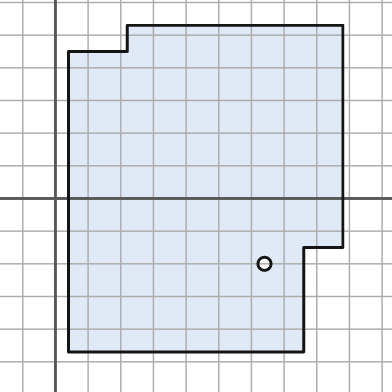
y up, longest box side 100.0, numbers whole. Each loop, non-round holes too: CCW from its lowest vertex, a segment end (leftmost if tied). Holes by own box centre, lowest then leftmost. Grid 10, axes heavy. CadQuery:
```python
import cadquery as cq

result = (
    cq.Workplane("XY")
    .moveTo(4.0, -47.0)
    .lineTo(76.0, -47.0)
    .lineTo(76.0, -15.0)
    .lineTo(88.0, -15.0)
    .lineTo(88.0, 53.0)
    .lineTo(22.0, 53.0)
    .lineTo(22.0, 45.0)
    .lineTo(4.0, 45.0)
    .close()
    .moveTo(64.0, -20.0)
    .circle(2.0)
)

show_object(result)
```